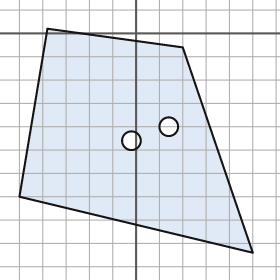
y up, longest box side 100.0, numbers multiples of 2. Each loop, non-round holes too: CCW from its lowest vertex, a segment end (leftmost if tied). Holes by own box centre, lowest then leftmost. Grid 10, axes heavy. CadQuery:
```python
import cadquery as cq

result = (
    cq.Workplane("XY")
    .moveTo(50.0, -94.0)
    .lineTo(20.0, -6.0)
    .lineTo(-38.0, 2.0)
    .lineTo(-50.0, -70.0)
    .close()
    .moveTo(-2.0, -46.0)
    .circle(4.0)
    .moveTo(14.0, -40.0)
    .circle(4.0)
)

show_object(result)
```